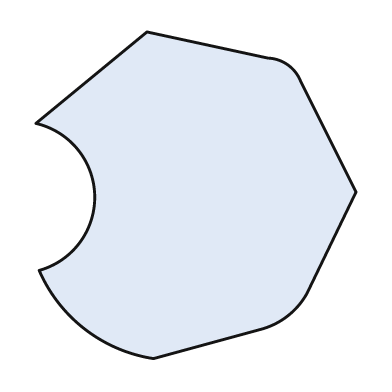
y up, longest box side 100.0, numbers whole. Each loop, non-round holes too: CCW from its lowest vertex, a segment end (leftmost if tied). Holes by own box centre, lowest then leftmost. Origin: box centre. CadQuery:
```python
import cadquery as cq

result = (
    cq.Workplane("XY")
    .moveTo(-13.0, -50.0)
    .lineTo(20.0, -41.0)
    .threePointArc((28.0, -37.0), (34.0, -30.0))
    .lineTo(49.0, 1.0)
    .lineTo(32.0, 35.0)
    .threePointArc((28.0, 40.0), (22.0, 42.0))
    .lineTo(-15.0, 50.0)
    .lineTo(-49.0, 22.0)
    .threePointArc((-31.0, 0.0), (-48.0, -23.0))
    .threePointArc((-34.0, -41.0), (-13.0, -50.0))
    .close()
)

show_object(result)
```